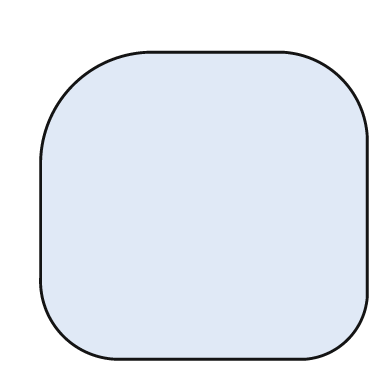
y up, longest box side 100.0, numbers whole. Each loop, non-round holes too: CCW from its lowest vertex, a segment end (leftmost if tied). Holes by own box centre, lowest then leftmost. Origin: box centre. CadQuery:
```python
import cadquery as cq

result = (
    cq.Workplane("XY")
    .moveTo(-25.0, -47.0)
    .lineTo(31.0, -47.0)
    .threePointArc((44.0, -41.0), (50.0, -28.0))
    .lineTo(50.0, 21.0)
    .threePointArc((42.0, 39.0), (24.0, 47.0))
    .lineTo(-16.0, 47.0)
    .threePointArc((-40.0, 37.0), (-50.0, 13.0))
    .lineTo(-50.0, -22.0)
    .threePointArc((-43.0, -40.0), (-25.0, -47.0))
    .close()
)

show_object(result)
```